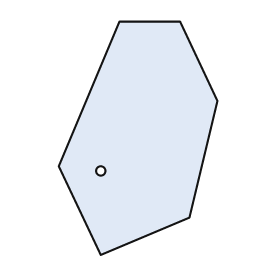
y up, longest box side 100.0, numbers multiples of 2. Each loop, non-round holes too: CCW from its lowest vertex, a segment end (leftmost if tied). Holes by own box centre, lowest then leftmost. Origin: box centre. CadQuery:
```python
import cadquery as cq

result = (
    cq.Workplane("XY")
    .moveTo(-16.0, -50.0)
    .lineTo(22.0, -34.0)
    .lineTo(34.0, 16.0)
    .lineTo(18.0, 50.0)
    .lineTo(-8.0, 50.0)
    .lineTo(-34.0, -12.0)
    .close()
    .moveTo(-16.0, -14.0)
    .circle(2.0)
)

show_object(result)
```